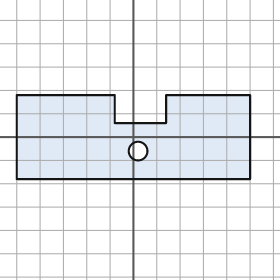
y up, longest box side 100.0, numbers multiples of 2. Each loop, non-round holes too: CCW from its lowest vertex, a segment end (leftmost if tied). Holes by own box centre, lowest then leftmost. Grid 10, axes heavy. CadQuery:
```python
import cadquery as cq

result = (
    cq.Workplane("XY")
    .moveTo(-50.0, -18.0)
    .lineTo(50.0, -18.0)
    .lineTo(50.0, 18.0)
    .lineTo(14.0, 18.0)
    .lineTo(14.0, 6.0)
    .lineTo(-8.0, 6.0)
    .lineTo(-8.0, 18.0)
    .lineTo(-50.0, 18.0)
    .close()
    .moveTo(2.0, -6.0)
    .circle(4.0)
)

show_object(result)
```